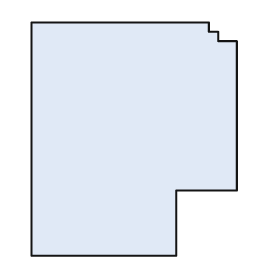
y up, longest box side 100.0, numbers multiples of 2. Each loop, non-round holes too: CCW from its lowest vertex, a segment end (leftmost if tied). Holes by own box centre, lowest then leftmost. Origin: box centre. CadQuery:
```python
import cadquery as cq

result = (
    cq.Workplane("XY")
    .moveTo(-44.0, -50.0)
    .lineTo(18.0, -50.0)
    .lineTo(18.0, -22.0)
    .lineTo(44.0, -22.0)
    .lineTo(44.0, 42.0)
    .lineTo(36.0, 42.0)
    .lineTo(36.0, 46.0)
    .lineTo(32.0, 46.0)
    .lineTo(32.0, 50.0)
    .lineTo(-44.0, 50.0)
    .close()
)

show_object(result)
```